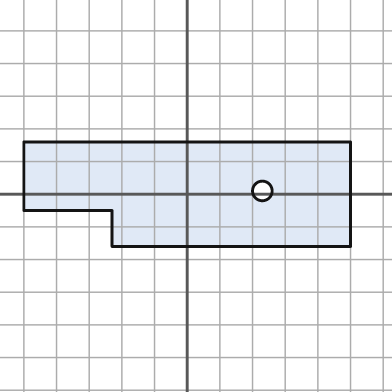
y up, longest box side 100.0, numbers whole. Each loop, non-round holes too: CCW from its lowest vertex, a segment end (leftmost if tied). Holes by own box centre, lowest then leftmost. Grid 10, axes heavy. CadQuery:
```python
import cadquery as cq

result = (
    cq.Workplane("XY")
    .moveTo(-23.0, -16.0)
    .lineTo(50.0, -16.0)
    .lineTo(50.0, 16.0)
    .lineTo(-50.0, 16.0)
    .lineTo(-50.0, -5.0)
    .lineTo(-23.0, -5.0)
    .close()
    .moveTo(23.0, 1.0)
    .circle(3.0)
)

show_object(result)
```